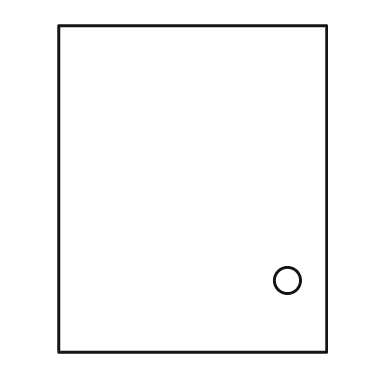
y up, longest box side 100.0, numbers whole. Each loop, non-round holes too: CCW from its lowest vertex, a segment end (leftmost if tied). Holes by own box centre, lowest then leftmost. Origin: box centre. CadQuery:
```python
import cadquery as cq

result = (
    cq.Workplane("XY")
    .moveTo(-41.0, -50.0)
    .lineTo(41.0, -50.0)
    .lineTo(41.0, 50.0)
    .lineTo(-41.0, 50.0)
    .close()
    .moveTo(29.0, -28.0)
    .circle(4.0)
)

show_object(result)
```